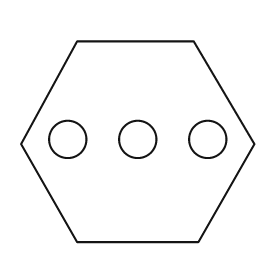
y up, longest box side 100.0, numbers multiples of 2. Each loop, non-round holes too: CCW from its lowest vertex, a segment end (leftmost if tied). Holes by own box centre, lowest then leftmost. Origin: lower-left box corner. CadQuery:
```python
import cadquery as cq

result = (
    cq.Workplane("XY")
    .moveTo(24.0, 0.0)
    .lineTo(76.0, 0.0)
    .lineTo(100.0, 42.0)
    .lineTo(74.0, 86.0)
    .lineTo(24.0, 86.0)
    .lineTo(0.0, 42.0)
    .close()
    .moveTo(20.0, 44.0)
    .circle(8.0)
    .moveTo(50.0, 44.0)
    .circle(8.0)
    .moveTo(80.0, 44.0)
    .circle(8.0)
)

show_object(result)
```